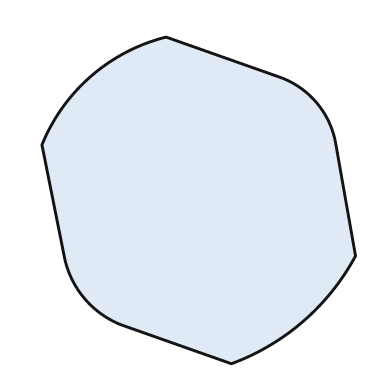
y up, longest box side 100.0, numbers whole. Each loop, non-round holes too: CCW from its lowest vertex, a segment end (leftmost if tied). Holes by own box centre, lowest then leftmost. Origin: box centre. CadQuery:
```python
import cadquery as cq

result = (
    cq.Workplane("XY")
    .moveTo(10.0, -50.0)
    .threePointArc((32.0, -37.0), (48.0, -17.0))
    .lineTo(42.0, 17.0)
    .threePointArc((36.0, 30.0), (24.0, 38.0))
    .lineTo(-10.0, 50.0)
    .threePointArc((-33.0, 38.0), (-48.0, 17.0))
    .lineTo(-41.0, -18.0)
    .threePointArc((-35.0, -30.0), (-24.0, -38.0))
    .close()
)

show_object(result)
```